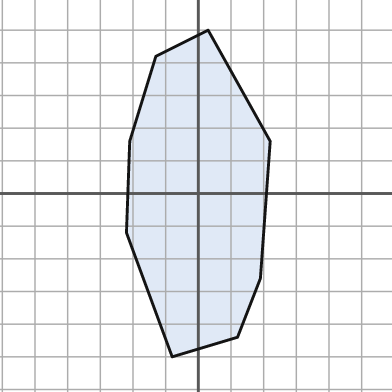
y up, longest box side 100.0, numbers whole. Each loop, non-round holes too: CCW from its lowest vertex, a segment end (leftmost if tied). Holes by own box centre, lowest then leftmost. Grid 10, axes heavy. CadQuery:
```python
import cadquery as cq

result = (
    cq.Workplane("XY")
    .moveTo(-8.0, -50.0)
    .lineTo(12.0, -44.0)
    .lineTo(19.0, -26.0)
    .lineTo(22.0, 16.0)
    .lineTo(3.0, 50.0)
    .lineTo(-13.0, 42.0)
    .lineTo(-21.0, 16.0)
    .lineTo(-22.0, -12.0)
    .close()
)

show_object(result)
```